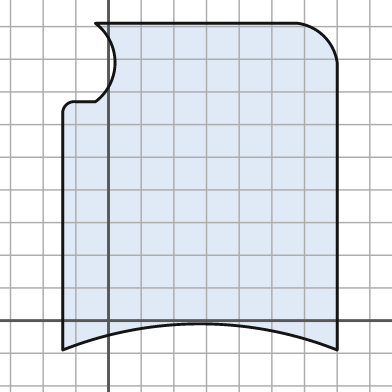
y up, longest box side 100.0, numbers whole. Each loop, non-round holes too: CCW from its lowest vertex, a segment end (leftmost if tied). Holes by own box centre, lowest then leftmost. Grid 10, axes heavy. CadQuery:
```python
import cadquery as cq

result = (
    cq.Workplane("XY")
    .moveTo(-14.0, -9.0)
    .threePointArc((28.0, -1.0), (70.0, -9.0))
    .lineTo(70.0, 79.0)
    .threePointArc((66.0, 87.0), (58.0, 91.0))
    .lineTo(-4.0, 91.0)
    .threePointArc((2.0, 79.0), (-4.0, 67.0))
    .lineTo(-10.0, 67.0)
    .threePointArc((-13.0, 66.0), (-14.0, 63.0))
    .close()
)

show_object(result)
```